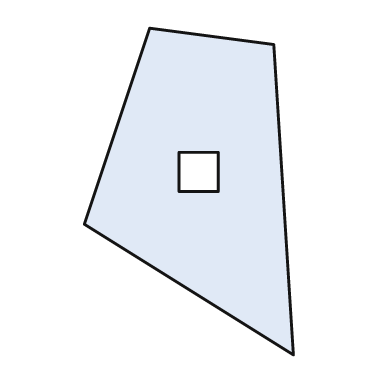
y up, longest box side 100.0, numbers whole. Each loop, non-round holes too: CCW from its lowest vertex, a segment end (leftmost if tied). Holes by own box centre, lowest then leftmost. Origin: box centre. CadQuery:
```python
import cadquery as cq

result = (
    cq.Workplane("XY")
    .moveTo(32.0, -50.0)
    .lineTo(26.0, 45.0)
    .lineTo(-12.0, 50.0)
    .lineTo(-32.0, -10.0)
    .close()
    .moveTo(-3.0, 0.0)
    .lineTo(9.0, 0.0)
    .lineTo(9.0, 12.0)
    .lineTo(-3.0, 12.0)
    .close()
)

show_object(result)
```